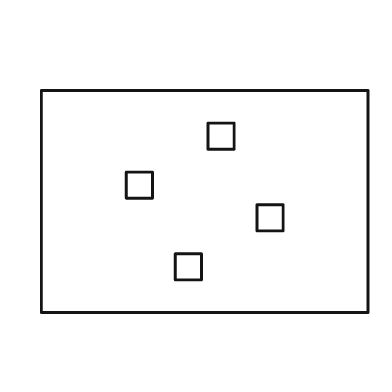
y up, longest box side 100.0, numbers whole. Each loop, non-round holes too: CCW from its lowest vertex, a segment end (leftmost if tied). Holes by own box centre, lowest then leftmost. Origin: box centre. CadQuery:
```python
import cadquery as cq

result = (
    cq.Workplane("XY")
    .moveTo(-50.0, -34.0)
    .lineTo(50.0, -34.0)
    .lineTo(50.0, 34.0)
    .lineTo(-50.0, 34.0)
    .close()
    .moveTo(-9.0, -24.0)
    .lineTo(-1.0, -24.0)
    .lineTo(-1.0, -16.0)
    .lineTo(-9.0, -16.0)
    .close()
    .moveTo(16.0, -9.0)
    .lineTo(24.0, -9.0)
    .lineTo(24.0, -1.0)
    .lineTo(16.0, -1.0)
    .close()
    .moveTo(-24.0, 1.0)
    .lineTo(-16.0, 1.0)
    .lineTo(-16.0, 9.0)
    .lineTo(-24.0, 9.0)
    .close()
    .moveTo(1.0, 16.0)
    .lineTo(9.0, 16.0)
    .lineTo(9.0, 24.0)
    .lineTo(1.0, 24.0)
    .close()
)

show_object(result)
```